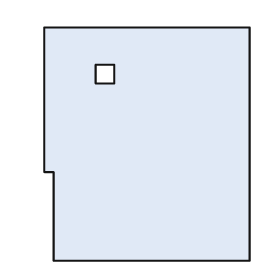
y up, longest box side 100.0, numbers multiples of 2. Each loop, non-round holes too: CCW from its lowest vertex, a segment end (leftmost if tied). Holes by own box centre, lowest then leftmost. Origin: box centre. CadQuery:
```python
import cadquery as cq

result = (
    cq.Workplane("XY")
    .moveTo(-40.0, -50.0)
    .lineTo(44.0, -50.0)
    .lineTo(44.0, 50.0)
    .lineTo(-44.0, 50.0)
    .lineTo(-44.0, -12.0)
    .lineTo(-40.0, -12.0)
    .close()
    .moveTo(-22.0, 26.0)
    .lineTo(-14.0, 26.0)
    .lineTo(-14.0, 34.0)
    .lineTo(-22.0, 34.0)
    .close()
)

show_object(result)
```